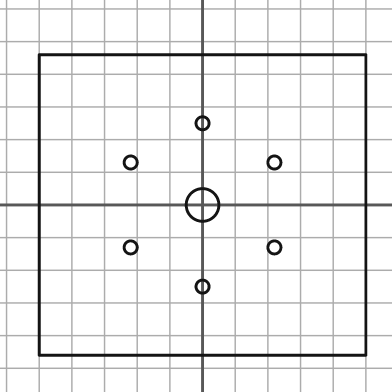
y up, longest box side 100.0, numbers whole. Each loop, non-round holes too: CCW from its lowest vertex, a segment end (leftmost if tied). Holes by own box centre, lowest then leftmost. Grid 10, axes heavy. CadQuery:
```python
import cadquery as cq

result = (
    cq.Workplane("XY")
    .moveTo(-50.0, -46.0)
    .lineTo(50.0, -46.0)
    .lineTo(50.0, 46.0)
    .lineTo(-50.0, 46.0)
    .close()
    .moveTo(0.0, -25.0)
    .circle(2.0)
    .moveTo(-22.0, -13.0)
    .circle(2.0)
    .moveTo(22.0, -13.0)
    .circle(2.0)
    .moveTo(0.0, 0.0)
    .circle(5.0)
    .moveTo(-22.0, 13.0)
    .circle(2.0)
    .moveTo(22.0, 13.0)
    .circle(2.0)
    .moveTo(0.0, 25.0)
    .circle(2.0)
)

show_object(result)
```